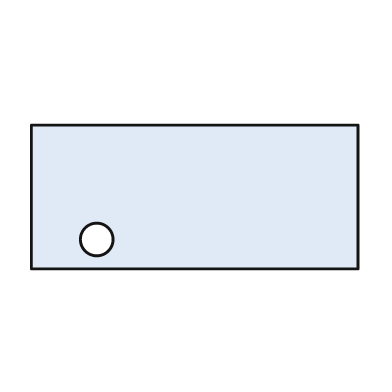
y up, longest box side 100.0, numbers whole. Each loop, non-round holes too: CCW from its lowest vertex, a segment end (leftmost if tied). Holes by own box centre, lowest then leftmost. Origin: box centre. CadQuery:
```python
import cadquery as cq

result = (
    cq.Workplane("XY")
    .moveTo(-50.0, -22.0)
    .lineTo(50.0, -22.0)
    .lineTo(50.0, 22.0)
    .lineTo(-50.0, 22.0)
    .close()
    .moveTo(-30.0, -13.0)
    .circle(5.0)
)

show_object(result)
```